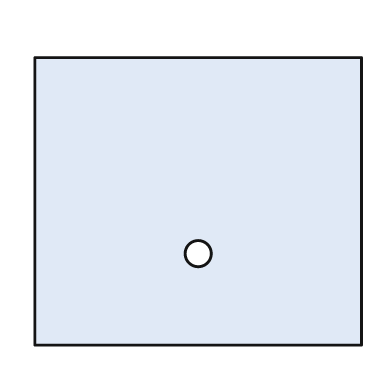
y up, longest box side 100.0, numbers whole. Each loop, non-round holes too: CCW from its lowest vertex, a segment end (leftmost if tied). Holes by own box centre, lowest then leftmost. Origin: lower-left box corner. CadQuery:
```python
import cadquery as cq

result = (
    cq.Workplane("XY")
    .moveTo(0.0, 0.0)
    .lineTo(100.0, 0.0)
    .lineTo(100.0, 88.0)
    .lineTo(0.0, 88.0)
    .close()
    .moveTo(50.0, 28.0)
    .circle(4.0)
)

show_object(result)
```